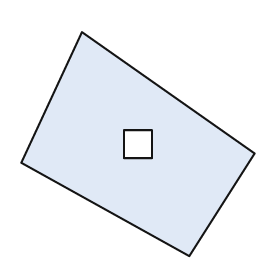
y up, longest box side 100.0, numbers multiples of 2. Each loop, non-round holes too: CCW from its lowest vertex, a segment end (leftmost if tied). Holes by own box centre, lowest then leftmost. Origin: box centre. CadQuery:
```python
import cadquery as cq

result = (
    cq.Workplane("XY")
    .moveTo(22.0, -48.0)
    .lineTo(50.0, -4.0)
    .lineTo(-24.0, 48.0)
    .lineTo(-50.0, -8.0)
    .close()
    .moveTo(-6.0, -6.0)
    .lineTo(6.0, -6.0)
    .lineTo(6.0, 6.0)
    .lineTo(-6.0, 6.0)
    .close()
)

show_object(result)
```